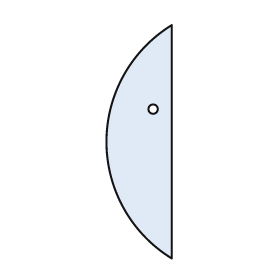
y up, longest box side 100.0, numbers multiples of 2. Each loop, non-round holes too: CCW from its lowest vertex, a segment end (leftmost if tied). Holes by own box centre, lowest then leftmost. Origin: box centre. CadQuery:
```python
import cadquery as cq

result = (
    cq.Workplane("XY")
    .moveTo(14.0, -50.0)
    .lineTo(14.0, 50.0)
    .threePointArc((-14.0, 0.0), (14.0, -50.0))
    .close()
    .moveTo(6.0, 14.0)
    .circle(2.0)
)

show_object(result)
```